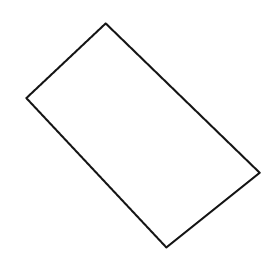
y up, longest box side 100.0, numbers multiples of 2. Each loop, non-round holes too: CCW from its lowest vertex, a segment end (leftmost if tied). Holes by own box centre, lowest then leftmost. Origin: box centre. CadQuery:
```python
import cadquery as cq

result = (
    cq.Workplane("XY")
    .moveTo(10.0, -48.0)
    .lineTo(50.0, -16.0)
    .lineTo(-16.0, 48.0)
    .lineTo(-50.0, 16.0)
    .close()
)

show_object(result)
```